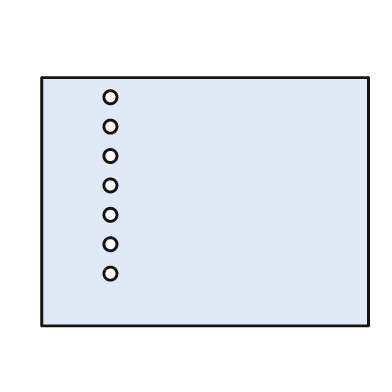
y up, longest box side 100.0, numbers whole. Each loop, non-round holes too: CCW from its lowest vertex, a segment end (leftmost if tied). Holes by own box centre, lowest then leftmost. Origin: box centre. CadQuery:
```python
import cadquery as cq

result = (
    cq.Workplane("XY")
    .moveTo(-50.0, -38.0)
    .lineTo(50.0, -38.0)
    .lineTo(50.0, 38.0)
    .lineTo(-50.0, 38.0)
    .close()
    .moveTo(-29.0, -22.0)
    .circle(2.0)
    .moveTo(-29.0, -13.0)
    .circle(2.0)
    .moveTo(-29.0, -4.0)
    .circle(2.0)
    .moveTo(-29.0, 5.0)
    .circle(2.0)
    .moveTo(-29.0, 14.0)
    .circle(2.0)
    .moveTo(-29.0, 23.0)
    .circle(2.0)
    .moveTo(-29.0, 32.0)
    .circle(2.0)
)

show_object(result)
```